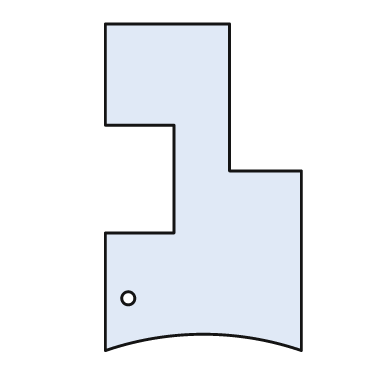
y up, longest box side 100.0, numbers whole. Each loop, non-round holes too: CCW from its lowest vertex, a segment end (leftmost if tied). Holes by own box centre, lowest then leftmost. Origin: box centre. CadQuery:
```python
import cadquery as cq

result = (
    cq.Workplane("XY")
    .moveTo(-30.0, -50.0)
    .threePointArc((0.0, -45.0), (30.0, -50.0))
    .lineTo(30.0, 5.0)
    .lineTo(8.0, 5.0)
    .lineTo(8.0, 50.0)
    .lineTo(-30.0, 50.0)
    .lineTo(-30.0, 19.0)
    .lineTo(-9.0, 19.0)
    .lineTo(-9.0, -14.0)
    .lineTo(-30.0, -14.0)
    .close()
    .moveTo(-23.0, -34.0)
    .circle(2.0)
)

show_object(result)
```